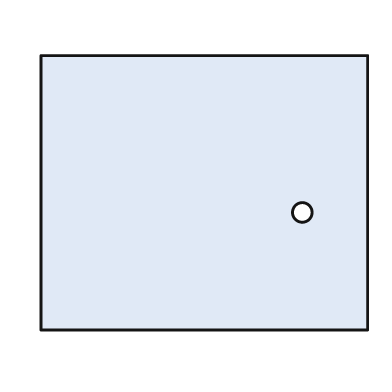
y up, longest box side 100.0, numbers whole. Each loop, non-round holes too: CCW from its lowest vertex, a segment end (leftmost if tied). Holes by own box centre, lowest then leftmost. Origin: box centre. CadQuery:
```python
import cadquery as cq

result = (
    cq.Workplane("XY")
    .moveTo(-50.0, -42.0)
    .lineTo(50.0, -42.0)
    .lineTo(50.0, 42.0)
    .lineTo(-50.0, 42.0)
    .close()
    .moveTo(30.0, -6.0)
    .circle(3.0)
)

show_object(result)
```